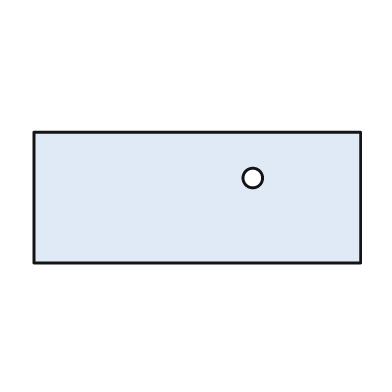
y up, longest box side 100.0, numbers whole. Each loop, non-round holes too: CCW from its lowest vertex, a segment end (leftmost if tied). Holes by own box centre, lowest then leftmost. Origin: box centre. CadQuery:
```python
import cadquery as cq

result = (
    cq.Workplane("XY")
    .moveTo(-50.0, -20.0)
    .lineTo(50.0, -20.0)
    .lineTo(50.0, 20.0)
    .lineTo(-50.0, 20.0)
    .close()
    .moveTo(17.0, 6.0)
    .circle(3.0)
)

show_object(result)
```